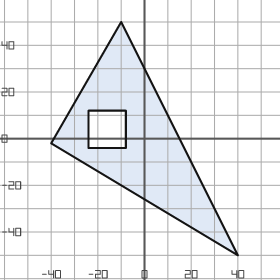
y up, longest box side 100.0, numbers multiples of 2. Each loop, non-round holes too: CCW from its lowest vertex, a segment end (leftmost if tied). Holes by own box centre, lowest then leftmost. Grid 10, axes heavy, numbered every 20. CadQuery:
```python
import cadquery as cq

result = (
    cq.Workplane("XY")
    .moveTo(40.0, -50.0)
    .lineTo(-10.0, 50.0)
    .lineTo(-40.0, -2.0)
    .close()
    .moveTo(-24.0, -4.0)
    .lineTo(-8.0, -4.0)
    .lineTo(-8.0, 12.0)
    .lineTo(-24.0, 12.0)
    .close()
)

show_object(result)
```